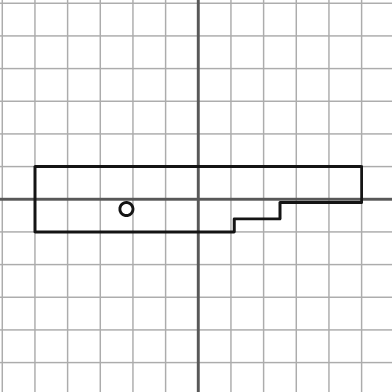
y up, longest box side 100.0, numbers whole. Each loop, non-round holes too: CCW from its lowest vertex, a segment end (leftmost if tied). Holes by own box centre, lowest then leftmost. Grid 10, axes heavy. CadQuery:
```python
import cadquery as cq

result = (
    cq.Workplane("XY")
    .moveTo(-50.0, -10.0)
    .lineTo(11.0, -10.0)
    .lineTo(11.0, -6.0)
    .lineTo(25.0, -6.0)
    .lineTo(25.0, -1.0)
    .lineTo(50.0, -1.0)
    .lineTo(50.0, 10.0)
    .lineTo(-50.0, 10.0)
    .close()
    .moveTo(-22.0, -3.0)
    .circle(2.0)
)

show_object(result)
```